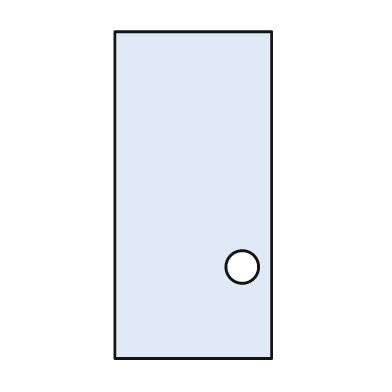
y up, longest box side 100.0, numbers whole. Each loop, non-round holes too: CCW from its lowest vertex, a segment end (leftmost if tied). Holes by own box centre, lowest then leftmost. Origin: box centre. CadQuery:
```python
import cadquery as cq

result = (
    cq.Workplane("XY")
    .moveTo(-24.0, -50.0)
    .lineTo(24.0, -50.0)
    .lineTo(24.0, 50.0)
    .lineTo(-24.0, 50.0)
    .close()
    .moveTo(15.0, -22.0)
    .circle(5.0)
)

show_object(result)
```